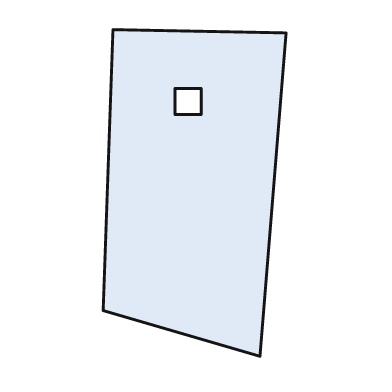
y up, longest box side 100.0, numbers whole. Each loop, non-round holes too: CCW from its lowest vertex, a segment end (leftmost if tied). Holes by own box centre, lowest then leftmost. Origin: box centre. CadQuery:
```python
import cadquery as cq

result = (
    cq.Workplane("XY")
    .moveTo(20.0, -50.0)
    .lineTo(28.0, 49.0)
    .lineTo(-25.0, 50.0)
    .lineTo(-28.0, -36.0)
    .close()
    .moveTo(-6.0, 24.0)
    .lineTo(2.0, 24.0)
    .lineTo(2.0, 32.0)
    .lineTo(-6.0, 32.0)
    .close()
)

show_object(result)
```